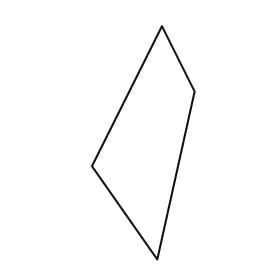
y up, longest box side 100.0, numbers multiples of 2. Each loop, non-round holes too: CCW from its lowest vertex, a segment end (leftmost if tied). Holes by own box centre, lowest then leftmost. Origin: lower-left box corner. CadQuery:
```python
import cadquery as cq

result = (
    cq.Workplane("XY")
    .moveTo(28.0, 0.0)
    .lineTo(44.0, 72.0)
    .lineTo(30.0, 100.0)
    .lineTo(0.0, 40.0)
    .close()
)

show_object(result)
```